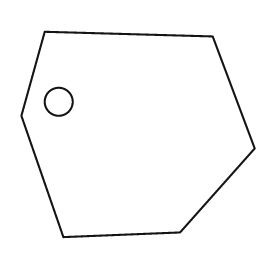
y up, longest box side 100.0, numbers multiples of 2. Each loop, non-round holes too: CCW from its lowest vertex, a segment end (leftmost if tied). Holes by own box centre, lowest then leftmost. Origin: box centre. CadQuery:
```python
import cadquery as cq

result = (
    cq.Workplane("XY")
    .moveTo(-32.0, -44.0)
    .lineTo(18.0, -42.0)
    .lineTo(50.0, -6.0)
    .lineTo(32.0, 42.0)
    .lineTo(-40.0, 44.0)
    .lineTo(-50.0, 8.0)
    .close()
    .moveTo(-34.0, 14.0)
    .circle(6.0)
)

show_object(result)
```